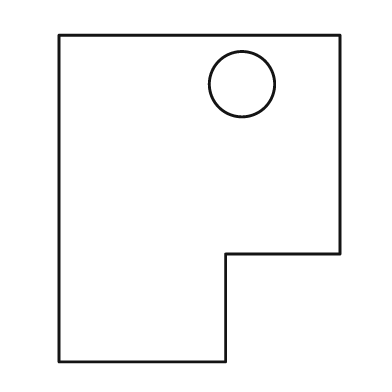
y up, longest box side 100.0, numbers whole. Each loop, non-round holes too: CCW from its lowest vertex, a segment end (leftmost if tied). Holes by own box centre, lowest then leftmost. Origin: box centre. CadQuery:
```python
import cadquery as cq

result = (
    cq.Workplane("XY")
    .moveTo(-43.0, -50.0)
    .lineTo(8.0, -50.0)
    .lineTo(8.0, -17.0)
    .lineTo(43.0, -17.0)
    .lineTo(43.0, 50.0)
    .lineTo(-43.0, 50.0)
    .close()
    .moveTo(13.0, 35.0)
    .circle(10.0)
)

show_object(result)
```